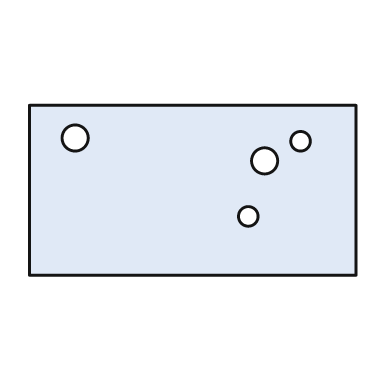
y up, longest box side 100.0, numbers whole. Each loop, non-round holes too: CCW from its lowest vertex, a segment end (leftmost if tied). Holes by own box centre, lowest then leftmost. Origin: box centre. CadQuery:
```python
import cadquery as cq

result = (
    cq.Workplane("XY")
    .moveTo(-50.0, -26.0)
    .lineTo(50.0, -26.0)
    .lineTo(50.0, 26.0)
    .lineTo(-50.0, 26.0)
    .close()
    .moveTo(17.0, -8.0)
    .circle(3.0)
    .moveTo(22.0, 9.0)
    .circle(4.0)
    .moveTo(33.0, 15.0)
    .circle(3.0)
    .moveTo(-36.0, 16.0)
    .circle(4.0)
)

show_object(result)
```